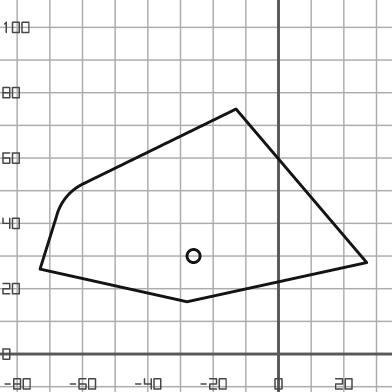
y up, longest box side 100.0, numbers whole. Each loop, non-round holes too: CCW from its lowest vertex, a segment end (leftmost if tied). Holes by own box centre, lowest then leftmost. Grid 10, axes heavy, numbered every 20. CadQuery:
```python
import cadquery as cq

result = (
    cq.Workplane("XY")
    .moveTo(-28.0, 16.0)
    .lineTo(27.0, 28.0)
    .lineTo(-13.0, 75.0)
    .lineTo(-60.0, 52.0)
    .threePointArc((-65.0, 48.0), (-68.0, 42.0))
    .lineTo(-73.0, 26.0)
    .close()
    .moveTo(-26.0, 30.0)
    .circle(2.0)
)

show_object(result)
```